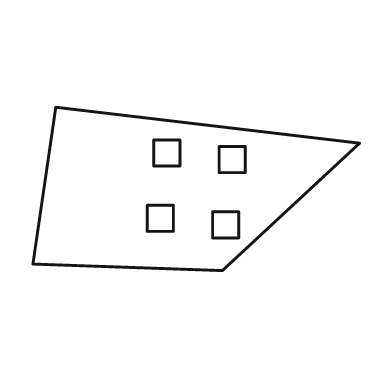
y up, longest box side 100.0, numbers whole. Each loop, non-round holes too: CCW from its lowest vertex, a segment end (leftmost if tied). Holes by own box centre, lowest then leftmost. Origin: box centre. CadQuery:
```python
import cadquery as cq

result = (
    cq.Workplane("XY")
    .moveTo(8.0, -25.0)
    .lineTo(50.0, 14.0)
    .lineTo(-43.0, 25.0)
    .lineTo(-50.0, -23.0)
    .close()
    .moveTo(5.0, -15.0)
    .lineTo(13.0, -15.0)
    .lineTo(13.0, -7.0)
    .lineTo(5.0, -7.0)
    .close()
    .moveTo(-15.0, -13.0)
    .lineTo(-7.0, -13.0)
    .lineTo(-7.0, -5.0)
    .lineTo(-15.0, -5.0)
    .close()
    .moveTo(7.0, 5.0)
    .lineTo(15.0, 5.0)
    .lineTo(15.0, 13.0)
    .lineTo(7.0, 13.0)
    .close()
    .moveTo(-13.0, 7.0)
    .lineTo(-5.0, 7.0)
    .lineTo(-5.0, 15.0)
    .lineTo(-13.0, 15.0)
    .close()
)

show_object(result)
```